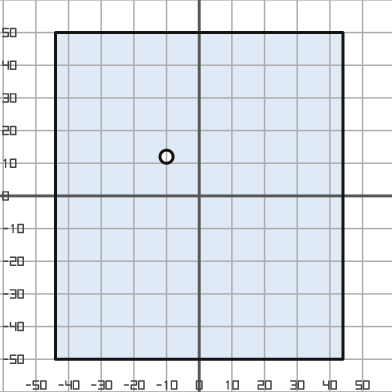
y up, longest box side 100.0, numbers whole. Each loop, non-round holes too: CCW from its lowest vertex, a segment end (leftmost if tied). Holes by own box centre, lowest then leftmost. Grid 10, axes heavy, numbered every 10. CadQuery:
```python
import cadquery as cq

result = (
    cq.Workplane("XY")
    .moveTo(-44.0, -50.0)
    .lineTo(44.0, -50.0)
    .lineTo(44.0, 50.0)
    .lineTo(-44.0, 50.0)
    .close()
    .moveTo(-10.0, 12.0)
    .circle(2.0)
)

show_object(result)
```